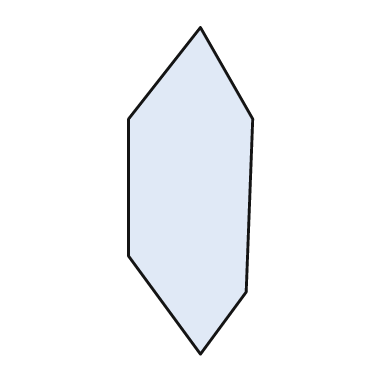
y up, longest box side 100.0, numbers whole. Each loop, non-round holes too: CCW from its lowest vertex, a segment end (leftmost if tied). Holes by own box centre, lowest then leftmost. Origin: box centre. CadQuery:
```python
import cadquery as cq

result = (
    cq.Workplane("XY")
    .moveTo(3.0, -50.0)
    .lineTo(17.0, -31.0)
    .lineTo(19.0, 22.0)
    .lineTo(3.0, 50.0)
    .lineTo(-19.0, 22.0)
    .lineTo(-19.0, -20.0)
    .close()
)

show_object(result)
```